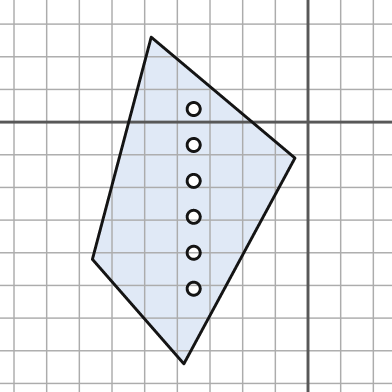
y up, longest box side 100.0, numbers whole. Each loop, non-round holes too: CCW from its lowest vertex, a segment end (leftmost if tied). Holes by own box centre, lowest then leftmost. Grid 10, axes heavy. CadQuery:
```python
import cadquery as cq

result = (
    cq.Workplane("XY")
    .moveTo(-38.0, -74.0)
    .lineTo(-4.0, -11.0)
    .lineTo(-48.0, 26.0)
    .lineTo(-66.0, -42.0)
    .close()
    .moveTo(-35.0, -51.0)
    .circle(2.0)
    .moveTo(-35.0, -40.0)
    .circle(2.0)
    .moveTo(-35.0, -29.0)
    .circle(2.0)
    .moveTo(-35.0, -18.0)
    .circle(2.0)
    .moveTo(-35.0, -7.0)
    .circle(2.0)
    .moveTo(-35.0, 4.0)
    .circle(2.0)
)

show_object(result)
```